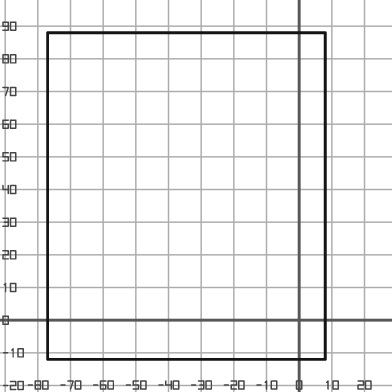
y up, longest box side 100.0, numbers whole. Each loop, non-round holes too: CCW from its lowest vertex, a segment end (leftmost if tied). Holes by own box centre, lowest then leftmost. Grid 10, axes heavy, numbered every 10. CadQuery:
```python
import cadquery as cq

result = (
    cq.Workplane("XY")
    .moveTo(-77.0, -12.0)
    .lineTo(8.0, -12.0)
    .lineTo(8.0, 88.0)
    .lineTo(-77.0, 88.0)
    .close()
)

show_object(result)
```